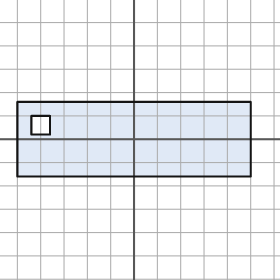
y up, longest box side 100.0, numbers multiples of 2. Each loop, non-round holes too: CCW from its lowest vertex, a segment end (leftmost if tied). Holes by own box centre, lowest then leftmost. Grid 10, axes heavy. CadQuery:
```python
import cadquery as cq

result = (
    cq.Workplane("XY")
    .moveTo(-50.0, -16.0)
    .lineTo(50.0, -16.0)
    .lineTo(50.0, 16.0)
    .lineTo(-50.0, 16.0)
    .close()
    .moveTo(-44.0, 2.0)
    .lineTo(-36.0, 2.0)
    .lineTo(-36.0, 10.0)
    .lineTo(-44.0, 10.0)
    .close()
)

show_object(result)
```